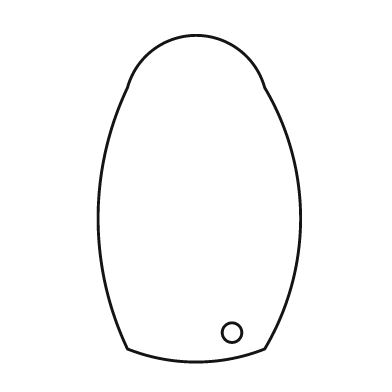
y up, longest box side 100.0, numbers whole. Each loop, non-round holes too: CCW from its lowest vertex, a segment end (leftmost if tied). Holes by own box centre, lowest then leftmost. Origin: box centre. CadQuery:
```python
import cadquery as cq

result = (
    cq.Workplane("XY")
    .moveTo(-22.0, -46.0)
    .threePointArc((-1.0, -50.0), (20.0, -46.0))
    .threePointArc((31.0, -6.0), (20.0, 34.0))
    .threePointArc((-1.0, 50.0), (-22.0, 34.0))
    .threePointArc((-31.0, -6.0), (-22.0, -46.0))
    .close()
    .moveTo(10.0, -41.0)
    .circle(3.0)
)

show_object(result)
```